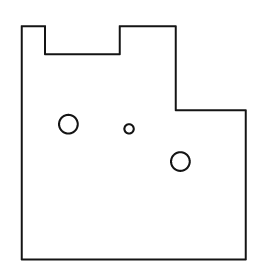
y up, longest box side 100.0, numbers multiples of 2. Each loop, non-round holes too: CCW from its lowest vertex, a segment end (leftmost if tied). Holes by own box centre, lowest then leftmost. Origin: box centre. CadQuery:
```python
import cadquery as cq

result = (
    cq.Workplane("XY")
    .moveTo(-48.0, -50.0)
    .lineTo(48.0, -50.0)
    .lineTo(48.0, 14.0)
    .lineTo(18.0, 14.0)
    .lineTo(18.0, 50.0)
    .lineTo(-6.0, 50.0)
    .lineTo(-6.0, 38.0)
    .lineTo(-38.0, 38.0)
    .lineTo(-38.0, 50.0)
    .lineTo(-48.0, 50.0)
    .close()
    .moveTo(20.0, -8.0)
    .circle(4.0)
    .moveTo(-2.0, 6.0)
    .circle(2.0)
    .moveTo(-28.0, 8.0)
    .circle(4.0)
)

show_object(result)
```